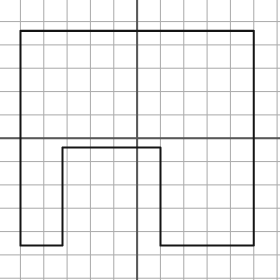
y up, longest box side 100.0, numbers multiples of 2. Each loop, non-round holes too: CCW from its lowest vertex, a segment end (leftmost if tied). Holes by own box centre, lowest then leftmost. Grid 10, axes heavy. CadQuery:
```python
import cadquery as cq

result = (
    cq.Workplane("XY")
    .moveTo(-50.0, -46.0)
    .lineTo(-32.0, -46.0)
    .lineTo(-32.0, -4.0)
    .lineTo(10.0, -4.0)
    .lineTo(10.0, -46.0)
    .lineTo(50.0, -46.0)
    .lineTo(50.0, 46.0)
    .lineTo(-50.0, 46.0)
    .close()
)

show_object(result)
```